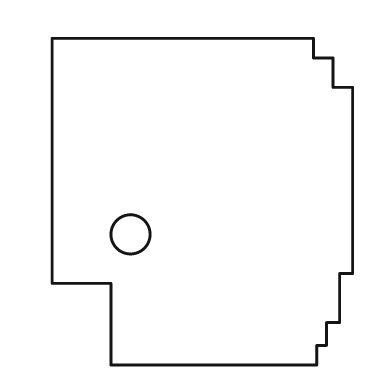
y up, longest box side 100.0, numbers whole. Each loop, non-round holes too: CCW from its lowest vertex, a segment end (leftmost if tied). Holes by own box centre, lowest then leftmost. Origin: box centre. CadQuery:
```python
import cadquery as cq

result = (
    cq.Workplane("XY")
    .moveTo(-28.0, -50.0)
    .lineTo(35.0, -50.0)
    .lineTo(35.0, -44.0)
    .lineTo(38.0, -44.0)
    .lineTo(38.0, -37.0)
    .lineTo(42.0, -37.0)
    .lineTo(42.0, -22.0)
    .lineTo(46.0, -22.0)
    .lineTo(46.0, 35.0)
    .lineTo(40.0, 35.0)
    .lineTo(40.0, 44.0)
    .lineTo(34.0, 44.0)
    .lineTo(34.0, 50.0)
    .lineTo(-46.0, 50.0)
    .lineTo(-46.0, -25.0)
    .lineTo(-28.0, -25.0)
    .close()
    .moveTo(-22.0, -10.0)
    .circle(6.0)
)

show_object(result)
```